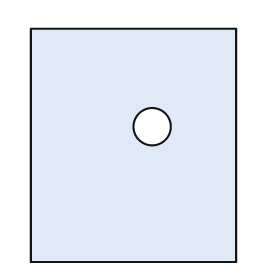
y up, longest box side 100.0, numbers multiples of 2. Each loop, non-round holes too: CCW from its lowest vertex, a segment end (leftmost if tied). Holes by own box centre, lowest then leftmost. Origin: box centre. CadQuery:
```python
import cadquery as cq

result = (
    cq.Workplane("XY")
    .moveTo(-44.0, -50.0)
    .lineTo(44.0, -50.0)
    .lineTo(44.0, 50.0)
    .lineTo(-44.0, 50.0)
    .close()
    .moveTo(8.0, 8.0)
    .circle(8.0)
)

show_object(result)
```